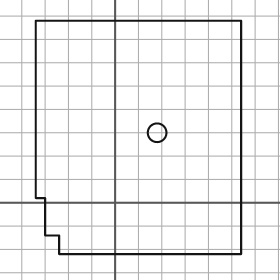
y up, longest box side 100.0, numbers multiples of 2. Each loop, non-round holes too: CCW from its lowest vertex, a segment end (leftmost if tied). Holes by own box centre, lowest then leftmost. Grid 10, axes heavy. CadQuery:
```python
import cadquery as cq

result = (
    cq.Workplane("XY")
    .moveTo(-24.0, -22.0)
    .lineTo(54.0, -22.0)
    .lineTo(54.0, 78.0)
    .lineTo(-34.0, 78.0)
    .lineTo(-34.0, 2.0)
    .lineTo(-30.0, 2.0)
    .lineTo(-30.0, -14.0)
    .lineTo(-24.0, -14.0)
    .close()
    .moveTo(18.0, 30.0)
    .circle(4.0)
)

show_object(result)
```